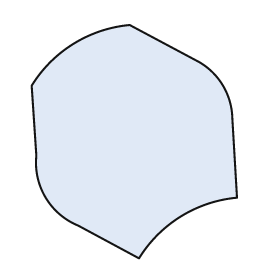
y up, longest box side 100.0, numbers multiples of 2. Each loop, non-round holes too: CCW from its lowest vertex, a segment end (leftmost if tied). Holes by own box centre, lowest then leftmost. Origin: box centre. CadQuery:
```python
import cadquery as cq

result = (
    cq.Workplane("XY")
    .moveTo(2.0, -50.0)
    .threePointArc((20.0, -32.0), (44.0, -24.0))
    .lineTo(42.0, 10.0)
    .threePointArc((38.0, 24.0), (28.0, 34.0))
    .lineTo(-2.0, 50.0)
    .threePointArc((-26.0, 42.0), (-44.0, 24.0))
    .lineTo(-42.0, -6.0)
    .threePointArc((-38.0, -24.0), (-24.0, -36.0))
    .close()
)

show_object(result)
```